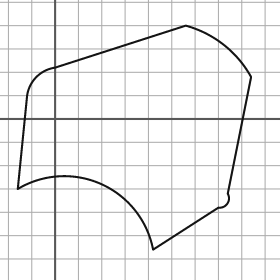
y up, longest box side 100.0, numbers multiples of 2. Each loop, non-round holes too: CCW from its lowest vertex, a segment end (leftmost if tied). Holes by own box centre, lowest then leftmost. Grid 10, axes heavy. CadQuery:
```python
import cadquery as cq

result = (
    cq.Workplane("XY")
    .moveTo(42.0, -56.0)
    .lineTo(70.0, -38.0)
    .threePointArc((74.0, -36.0), (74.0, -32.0))
    .lineTo(84.0, 18.0)
    .threePointArc((72.0, 32.0), (56.0, 40.0))
    .lineTo(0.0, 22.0)
    .threePointArc((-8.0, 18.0), (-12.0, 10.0))
    .lineTo(-16.0, -30.0)
    .threePointArc((20.0, -28.0), (42.0, -56.0))
    .close()
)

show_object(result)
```